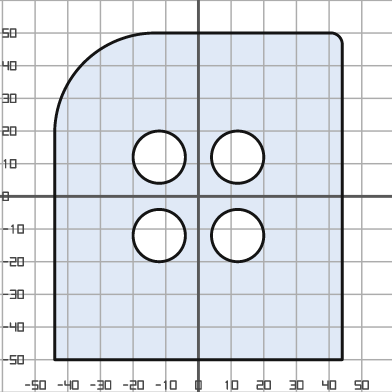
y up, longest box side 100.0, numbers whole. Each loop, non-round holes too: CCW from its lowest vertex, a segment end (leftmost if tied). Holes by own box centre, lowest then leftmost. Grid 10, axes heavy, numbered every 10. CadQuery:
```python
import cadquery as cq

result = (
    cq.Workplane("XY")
    .moveTo(-44.0, -50.0)
    .lineTo(44.0, -50.0)
    .lineTo(44.0, 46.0)
    .threePointArc((43.0, 49.0), (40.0, 50.0))
    .lineTo(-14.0, 50.0)
    .threePointArc((-35.0, 41.0), (-44.0, 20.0))
    .close()
    .moveTo(-12.0, -12.0)
    .circle(8.0)
    .moveTo(12.0, -12.0)
    .circle(8.0)
    .moveTo(-12.0, 12.0)
    .circle(8.0)
    .moveTo(12.0, 12.0)
    .circle(8.0)
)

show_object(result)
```